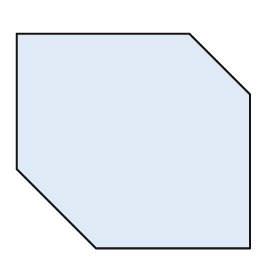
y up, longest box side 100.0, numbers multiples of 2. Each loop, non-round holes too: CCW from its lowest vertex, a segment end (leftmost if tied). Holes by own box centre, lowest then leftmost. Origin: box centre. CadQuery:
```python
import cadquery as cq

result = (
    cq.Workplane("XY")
    .moveTo(-16.0, -46.0)
    .lineTo(50.0, -46.0)
    .lineTo(50.0, 20.0)
    .lineTo(24.0, 46.0)
    .lineTo(-50.0, 46.0)
    .lineTo(-50.0, -12.0)
    .close()
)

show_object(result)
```